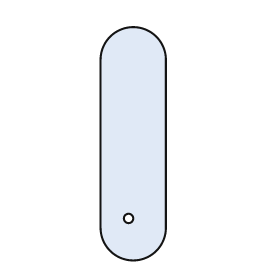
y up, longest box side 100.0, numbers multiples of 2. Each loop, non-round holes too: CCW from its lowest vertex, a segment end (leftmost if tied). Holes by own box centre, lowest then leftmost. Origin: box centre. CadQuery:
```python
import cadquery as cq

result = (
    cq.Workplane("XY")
    .moveTo(-14.0, -36.0)
    .threePointArc((0.0, -50.0), (14.0, -36.0))
    .lineTo(14.0, 36.0)
    .threePointArc((0.0, 50.0), (-14.0, 36.0))
    .close()
    .moveTo(-2.0, -32.0)
    .circle(2.0)
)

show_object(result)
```